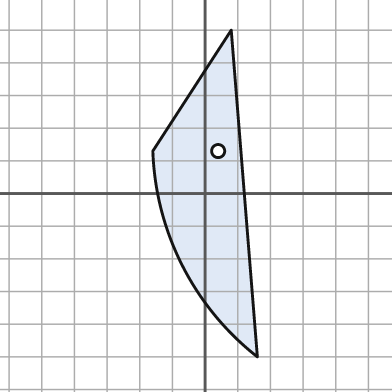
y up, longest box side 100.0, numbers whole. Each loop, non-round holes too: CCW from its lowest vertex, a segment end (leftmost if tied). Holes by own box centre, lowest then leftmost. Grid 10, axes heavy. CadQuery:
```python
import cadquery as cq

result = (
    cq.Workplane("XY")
    .moveTo(16.0, -50.0)
    .lineTo(8.0, 50.0)
    .lineTo(-16.0, 13.0)
    .threePointArc((-7.0, -22.0), (16.0, -50.0))
    .close()
    .moveTo(4.0, 13.0)
    .circle(2.0)
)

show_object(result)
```